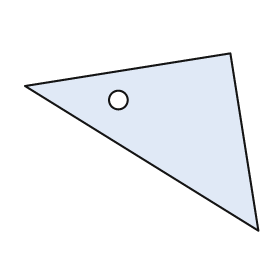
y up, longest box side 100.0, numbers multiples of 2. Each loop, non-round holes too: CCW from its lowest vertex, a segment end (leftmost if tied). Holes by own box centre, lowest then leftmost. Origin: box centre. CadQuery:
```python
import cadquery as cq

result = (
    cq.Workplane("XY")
    .moveTo(50.0, -38.0)
    .lineTo(38.0, 38.0)
    .lineTo(-50.0, 24.0)
    .close()
    .moveTo(-10.0, 18.0)
    .circle(4.0)
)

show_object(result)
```